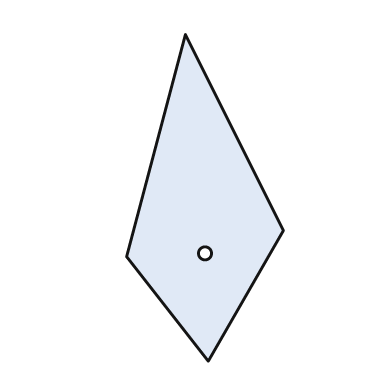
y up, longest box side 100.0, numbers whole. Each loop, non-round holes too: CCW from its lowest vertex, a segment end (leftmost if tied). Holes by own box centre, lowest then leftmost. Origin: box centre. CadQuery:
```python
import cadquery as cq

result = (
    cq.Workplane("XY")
    .moveTo(1.0, -50.0)
    .lineTo(24.0, -10.0)
    .lineTo(-6.0, 50.0)
    .lineTo(-24.0, -18.0)
    .close()
    .moveTo(0.0, -17.0)
    .circle(2.0)
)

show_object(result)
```